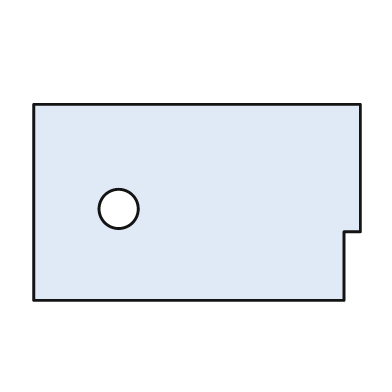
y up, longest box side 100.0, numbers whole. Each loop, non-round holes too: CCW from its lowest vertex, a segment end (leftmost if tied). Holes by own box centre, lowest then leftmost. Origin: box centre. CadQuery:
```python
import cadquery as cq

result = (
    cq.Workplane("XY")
    .moveTo(-50.0, -30.0)
    .lineTo(45.0, -30.0)
    .lineTo(45.0, -9.0)
    .lineTo(50.0, -9.0)
    .lineTo(50.0, 30.0)
    .lineTo(-50.0, 30.0)
    .close()
    .moveTo(-24.0, -2.0)
    .circle(6.0)
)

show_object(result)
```